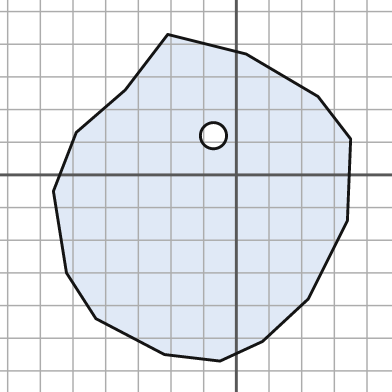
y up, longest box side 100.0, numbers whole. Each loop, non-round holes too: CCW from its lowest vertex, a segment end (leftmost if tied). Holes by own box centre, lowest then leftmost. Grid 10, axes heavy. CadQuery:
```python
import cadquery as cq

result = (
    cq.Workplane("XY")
    .moveTo(-5.0, -57.0)
    .lineTo(8.0, -51.0)
    .lineTo(22.0, -38.0)
    .lineTo(34.0, -14.0)
    .lineTo(35.0, 11.0)
    .lineTo(25.0, 24.0)
    .lineTo(3.0, 37.0)
    .lineTo(-21.0, 43.0)
    .lineTo(-34.0, 26.0)
    .lineTo(-49.0, 13.0)
    .lineTo(-56.0, -5.0)
    .lineTo(-52.0, -30.0)
    .lineTo(-43.0, -44.0)
    .lineTo(-22.0, -55.0)
    .close()
    .moveTo(-7.0, 12.0)
    .circle(4.0)
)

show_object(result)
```